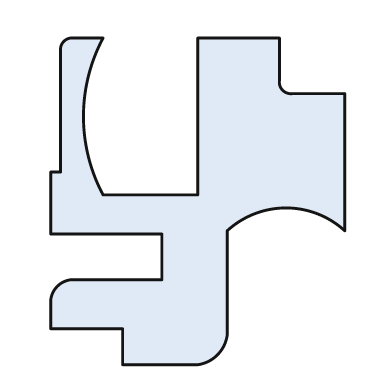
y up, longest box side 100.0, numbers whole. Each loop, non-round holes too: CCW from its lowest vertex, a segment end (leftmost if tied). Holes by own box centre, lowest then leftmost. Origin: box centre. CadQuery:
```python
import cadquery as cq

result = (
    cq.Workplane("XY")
    .moveTo(-23.0, -50.0)
    .lineTo(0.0, -50.0)
    .threePointArc((6.0, -47.0), (9.0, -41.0))
    .lineTo(9.0, -9.0)
    .threePointArc((27.0, -2.0), (45.0, -9.0))
    .lineTo(45.0, 33.0)
    .lineTo(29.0, 33.0)
    .threePointArc((26.0, 34.0), (25.0, 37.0))
    .lineTo(25.0, 50.0)
    .lineTo(0.0, 50.0)
    .lineTo(0.0, 2.0)
    .lineTo(-29.0, 2.0)
    .threePointArc((-35.0, 26.0), (-29.0, 50.0))
    .lineTo(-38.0, 50.0)
    .threePointArc((-41.0, 49.0), (-42.0, 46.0))
    .lineTo(-42.0, 9.0)
    .lineTo(-45.0, 9.0)
    .lineTo(-45.0, -10.0)
    .lineTo(-11.0, -10.0)
    .lineTo(-11.0, -24.0)
    .lineTo(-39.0, -24.0)
    .threePointArc((-43.0, -26.0), (-45.0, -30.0))
    .lineTo(-45.0, -39.0)
    .lineTo(-23.0, -39.0)
    .close()
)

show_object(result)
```